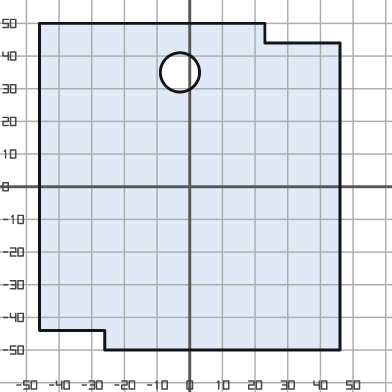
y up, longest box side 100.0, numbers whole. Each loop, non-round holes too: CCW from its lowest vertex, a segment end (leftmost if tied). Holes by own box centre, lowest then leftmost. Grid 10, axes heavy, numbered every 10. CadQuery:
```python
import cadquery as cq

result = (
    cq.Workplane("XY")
    .moveTo(-26.0, -50.0)
    .lineTo(46.0, -50.0)
    .lineTo(46.0, 44.0)
    .lineTo(23.0, 44.0)
    .lineTo(23.0, 50.0)
    .lineTo(-46.0, 50.0)
    .lineTo(-46.0, -44.0)
    .lineTo(-26.0, -44.0)
    .close()
    .moveTo(-3.0, 35.0)
    .circle(6.0)
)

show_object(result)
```